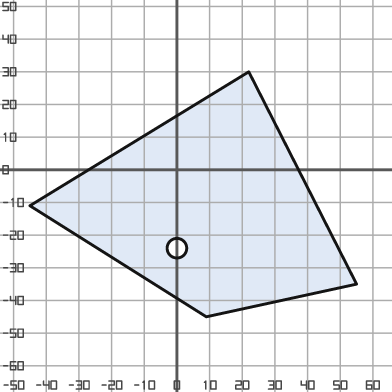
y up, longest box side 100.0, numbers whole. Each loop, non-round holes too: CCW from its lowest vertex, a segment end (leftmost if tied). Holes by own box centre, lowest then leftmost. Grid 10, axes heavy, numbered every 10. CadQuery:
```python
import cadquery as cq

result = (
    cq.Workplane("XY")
    .moveTo(9.0, -45.0)
    .lineTo(55.0, -35.0)
    .lineTo(22.0, 30.0)
    .lineTo(-45.0, -11.0)
    .close()
    .moveTo(0.0, -24.0)
    .circle(3.0)
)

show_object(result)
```